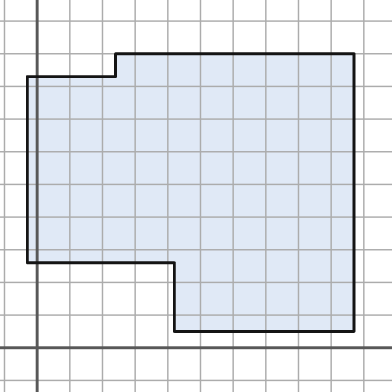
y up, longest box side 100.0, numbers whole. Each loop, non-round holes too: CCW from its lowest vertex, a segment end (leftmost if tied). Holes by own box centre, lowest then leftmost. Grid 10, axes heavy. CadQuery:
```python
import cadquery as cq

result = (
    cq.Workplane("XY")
    .moveTo(42.0, 5.0)
    .lineTo(97.0, 5.0)
    .lineTo(97.0, 90.0)
    .lineTo(24.0, 90.0)
    .lineTo(24.0, 83.0)
    .lineTo(-3.0, 83.0)
    .lineTo(-3.0, 26.0)
    .lineTo(42.0, 26.0)
    .close()
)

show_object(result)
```